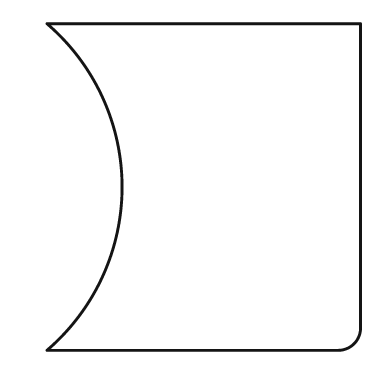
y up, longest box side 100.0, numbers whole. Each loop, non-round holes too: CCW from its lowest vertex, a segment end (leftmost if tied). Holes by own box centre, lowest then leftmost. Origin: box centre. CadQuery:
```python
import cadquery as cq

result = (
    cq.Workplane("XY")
    .moveTo(-48.0, -50.0)
    .lineTo(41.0, -50.0)
    .threePointArc((46.0, -48.0), (48.0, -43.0))
    .lineTo(48.0, 50.0)
    .lineTo(-48.0, 50.0)
    .threePointArc((-25.0, 0.0), (-48.0, -50.0))
    .close()
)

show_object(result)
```